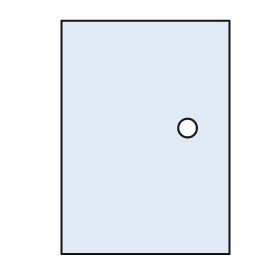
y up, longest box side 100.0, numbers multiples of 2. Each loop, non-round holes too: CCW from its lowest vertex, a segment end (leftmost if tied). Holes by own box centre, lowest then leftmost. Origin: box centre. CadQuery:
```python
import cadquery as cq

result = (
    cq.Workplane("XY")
    .moveTo(-36.0, -50.0)
    .lineTo(36.0, -50.0)
    .lineTo(36.0, 50.0)
    .lineTo(-36.0, 50.0)
    .close()
    .moveTo(18.0, 4.0)
    .circle(4.0)
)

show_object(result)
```